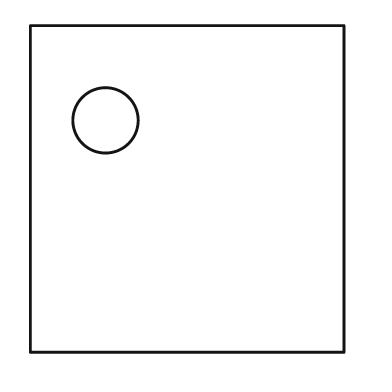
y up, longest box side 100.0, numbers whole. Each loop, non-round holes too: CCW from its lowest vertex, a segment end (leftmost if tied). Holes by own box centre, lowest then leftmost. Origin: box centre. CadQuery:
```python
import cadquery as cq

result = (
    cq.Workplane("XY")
    .moveTo(-48.0, -50.0)
    .lineTo(48.0, -50.0)
    .lineTo(48.0, 50.0)
    .lineTo(-48.0, 50.0)
    .close()
    .moveTo(-25.0, 21.0)
    .circle(10.0)
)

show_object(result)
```